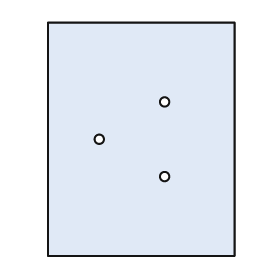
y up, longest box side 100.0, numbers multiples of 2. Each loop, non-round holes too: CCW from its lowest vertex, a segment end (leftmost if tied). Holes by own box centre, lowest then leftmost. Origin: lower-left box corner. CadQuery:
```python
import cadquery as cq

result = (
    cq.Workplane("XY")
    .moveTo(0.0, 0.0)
    .lineTo(80.0, 0.0)
    .lineTo(80.0, 100.0)
    .lineTo(0.0, 100.0)
    .close()
    .moveTo(50.0, 34.0)
    .circle(2.0)
    .moveTo(22.0, 50.0)
    .circle(2.0)
    .moveTo(50.0, 66.0)
    .circle(2.0)
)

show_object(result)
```